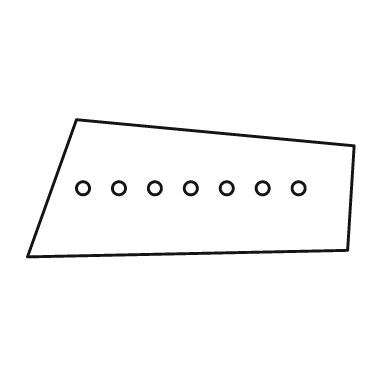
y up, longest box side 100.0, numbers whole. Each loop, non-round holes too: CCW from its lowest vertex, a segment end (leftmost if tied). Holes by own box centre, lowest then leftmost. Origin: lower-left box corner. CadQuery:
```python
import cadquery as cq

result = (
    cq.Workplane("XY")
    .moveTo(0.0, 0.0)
    .lineTo(98.0, 2.0)
    .lineTo(100.0, 34.0)
    .lineTo(15.0, 42.0)
    .close()
    .moveTo(17.0, 21.0)
    .circle(2.0)
    .moveTo(28.0, 21.0)
    .circle(2.0)
    .moveTo(39.0, 21.0)
    .circle(2.0)
    .moveTo(50.0, 21.0)
    .circle(2.0)
    .moveTo(61.0, 21.0)
    .circle(2.0)
    .moveTo(72.0, 21.0)
    .circle(2.0)
    .moveTo(83.0, 21.0)
    .circle(2.0)
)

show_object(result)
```